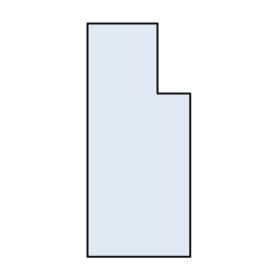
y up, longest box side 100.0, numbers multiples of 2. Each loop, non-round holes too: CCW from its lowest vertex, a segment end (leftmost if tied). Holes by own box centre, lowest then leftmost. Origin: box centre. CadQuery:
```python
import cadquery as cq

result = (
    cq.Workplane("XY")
    .moveTo(-22.0, -50.0)
    .lineTo(22.0, -50.0)
    .lineTo(22.0, 20.0)
    .lineTo(8.0, 20.0)
    .lineTo(8.0, 50.0)
    .lineTo(-22.0, 50.0)
    .close()
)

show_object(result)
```